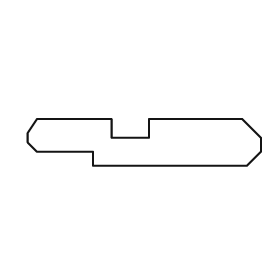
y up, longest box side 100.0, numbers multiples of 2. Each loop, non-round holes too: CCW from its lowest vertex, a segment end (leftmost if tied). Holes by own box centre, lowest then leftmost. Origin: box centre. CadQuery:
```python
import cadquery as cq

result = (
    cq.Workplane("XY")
    .moveTo(-22.0, -10.0)
    .lineTo(44.0, -10.0)
    .lineTo(50.0, -4.0)
    .lineTo(50.0, 2.0)
    .lineTo(42.0, 10.0)
    .lineTo(2.0, 10.0)
    .lineTo(2.0, 2.0)
    .lineTo(-14.0, 2.0)
    .lineTo(-14.0, 10.0)
    .lineTo(-46.0, 10.0)
    .lineTo(-50.0, 4.0)
    .lineTo(-50.0, 0.0)
    .lineTo(-46.0, -4.0)
    .lineTo(-22.0, -4.0)
    .close()
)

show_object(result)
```